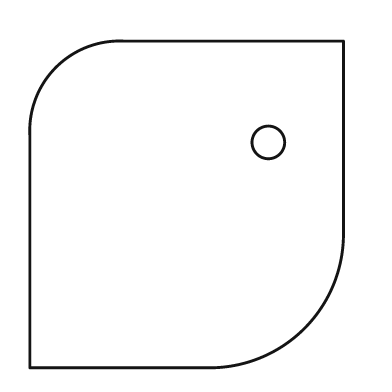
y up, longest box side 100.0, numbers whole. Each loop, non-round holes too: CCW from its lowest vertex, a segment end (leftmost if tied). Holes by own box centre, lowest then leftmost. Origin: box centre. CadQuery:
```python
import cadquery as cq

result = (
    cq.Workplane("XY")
    .moveTo(-48.0, -50.0)
    .lineTo(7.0, -50.0)
    .threePointArc((36.0, -38.0), (48.0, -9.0))
    .lineTo(48.0, 50.0)
    .lineTo(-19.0, 50.0)
    .threePointArc((-40.0, 42.0), (-48.0, 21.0))
    .close()
    .moveTo(25.0, 19.0)
    .circle(5.0)
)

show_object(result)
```